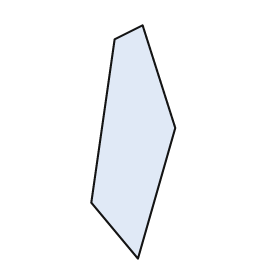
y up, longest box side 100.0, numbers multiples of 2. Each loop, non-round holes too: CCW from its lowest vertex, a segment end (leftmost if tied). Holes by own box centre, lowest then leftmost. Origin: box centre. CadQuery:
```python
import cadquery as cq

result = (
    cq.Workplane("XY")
    .moveTo(2.0, -50.0)
    .lineTo(18.0, 6.0)
    .lineTo(4.0, 50.0)
    .lineTo(-8.0, 44.0)
    .lineTo(-18.0, -26.0)
    .close()
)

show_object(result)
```